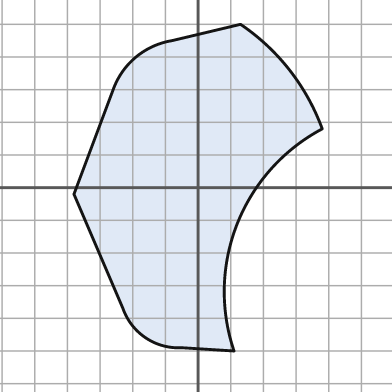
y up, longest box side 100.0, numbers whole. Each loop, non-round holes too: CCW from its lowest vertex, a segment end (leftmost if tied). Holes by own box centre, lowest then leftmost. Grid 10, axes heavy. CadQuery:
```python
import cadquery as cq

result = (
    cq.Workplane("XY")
    .moveTo(11.0, -50.0)
    .threePointArc((12.0, -11.0), (38.0, 18.0))
    .threePointArc((28.0, 36.0), (13.0, 50.0))
    .lineTo(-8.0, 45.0)
    .threePointArc((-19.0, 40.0), (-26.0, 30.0))
    .lineTo(-38.0, -2.0)
    .lineTo(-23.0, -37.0)
    .threePointArc((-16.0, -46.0), (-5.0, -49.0))
    .close()
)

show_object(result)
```